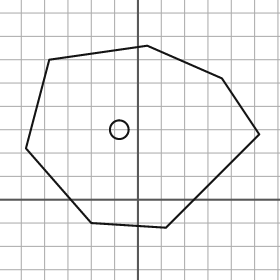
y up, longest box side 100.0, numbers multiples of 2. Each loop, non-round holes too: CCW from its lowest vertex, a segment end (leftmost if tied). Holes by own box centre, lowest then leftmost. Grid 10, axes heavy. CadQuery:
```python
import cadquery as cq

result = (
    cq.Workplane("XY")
    .moveTo(12.0, -12.0)
    .lineTo(52.0, 28.0)
    .lineTo(36.0, 52.0)
    .lineTo(4.0, 66.0)
    .lineTo(-38.0, 60.0)
    .lineTo(-48.0, 22.0)
    .lineTo(-20.0, -10.0)
    .close()
    .moveTo(-8.0, 30.0)
    .circle(4.0)
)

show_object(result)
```